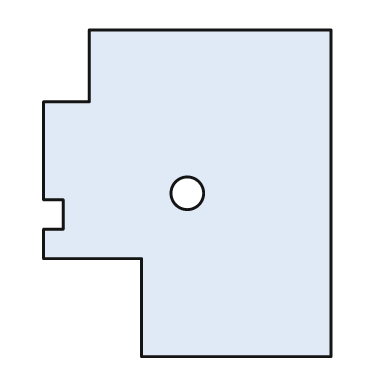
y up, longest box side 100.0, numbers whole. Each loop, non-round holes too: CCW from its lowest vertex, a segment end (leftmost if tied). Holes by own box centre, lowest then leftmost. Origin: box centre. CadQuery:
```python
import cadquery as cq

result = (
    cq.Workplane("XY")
    .moveTo(-14.0, -50.0)
    .lineTo(44.0, -50.0)
    .lineTo(44.0, 50.0)
    .lineTo(-30.0, 50.0)
    .lineTo(-30.0, 28.0)
    .lineTo(-44.0, 28.0)
    .lineTo(-44.0, -2.0)
    .lineTo(-38.0, -2.0)
    .lineTo(-38.0, -11.0)
    .lineTo(-44.0, -11.0)
    .lineTo(-44.0, -20.0)
    .lineTo(-14.0, -20.0)
    .close()
    .moveTo(0.0, 0.0)
    .circle(5.0)
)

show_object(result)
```